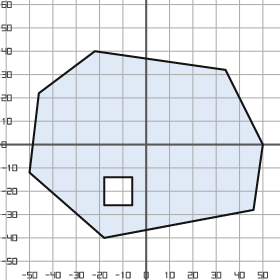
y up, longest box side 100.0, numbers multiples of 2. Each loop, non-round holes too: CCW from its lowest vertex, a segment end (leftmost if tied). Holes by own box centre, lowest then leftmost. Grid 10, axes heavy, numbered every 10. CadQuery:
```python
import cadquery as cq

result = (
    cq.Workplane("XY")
    .moveTo(-18.0, -40.0)
    .lineTo(46.0, -28.0)
    .lineTo(50.0, 0.0)
    .lineTo(34.0, 32.0)
    .lineTo(-22.0, 40.0)
    .lineTo(-46.0, 22.0)
    .lineTo(-50.0, -12.0)
    .close()
    .moveTo(-18.0, -26.0)
    .lineTo(-6.0, -26.0)
    .lineTo(-6.0, -14.0)
    .lineTo(-18.0, -14.0)
    .close()
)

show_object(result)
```